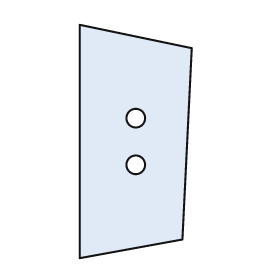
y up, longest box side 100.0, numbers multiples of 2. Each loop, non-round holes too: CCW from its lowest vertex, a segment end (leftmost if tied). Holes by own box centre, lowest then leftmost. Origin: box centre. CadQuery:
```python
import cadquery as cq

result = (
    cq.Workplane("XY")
    .moveTo(-24.0, -50.0)
    .lineTo(20.0, -42.0)
    .lineTo(24.0, 40.0)
    .lineTo(-24.0, 50.0)
    .close()
    .moveTo(0.0, -10.0)
    .circle(4.0)
    .moveTo(0.0, 10.0)
    .circle(4.0)
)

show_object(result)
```